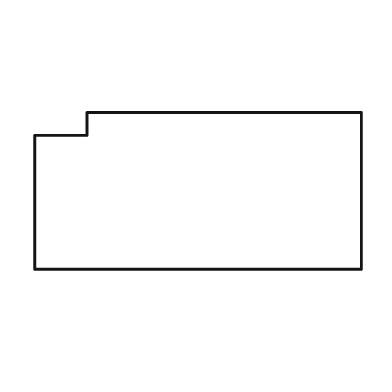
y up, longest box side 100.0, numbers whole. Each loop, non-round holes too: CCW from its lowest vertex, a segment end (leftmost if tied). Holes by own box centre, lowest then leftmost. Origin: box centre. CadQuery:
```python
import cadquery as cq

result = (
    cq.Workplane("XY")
    .moveTo(-50.0, -24.0)
    .lineTo(50.0, -24.0)
    .lineTo(50.0, 24.0)
    .lineTo(-34.0, 24.0)
    .lineTo(-34.0, 17.0)
    .lineTo(-50.0, 17.0)
    .close()
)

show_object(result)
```